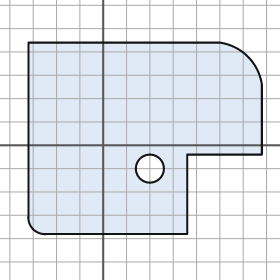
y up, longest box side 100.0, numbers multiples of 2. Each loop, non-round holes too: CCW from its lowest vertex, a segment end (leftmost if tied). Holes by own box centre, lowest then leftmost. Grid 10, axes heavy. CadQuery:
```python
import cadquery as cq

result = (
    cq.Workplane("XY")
    .moveTo(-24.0, -38.0)
    .lineTo(36.0, -38.0)
    .lineTo(36.0, -4.0)
    .lineTo(68.0, -4.0)
    .lineTo(68.0, 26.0)
    .threePointArc((62.0, 38.0), (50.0, 44.0))
    .lineTo(-32.0, 44.0)
    .lineTo(-32.0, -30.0)
    .threePointArc((-30.0, -36.0), (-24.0, -38.0))
    .close()
    .moveTo(20.0, -10.0)
    .circle(6.0)
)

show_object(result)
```